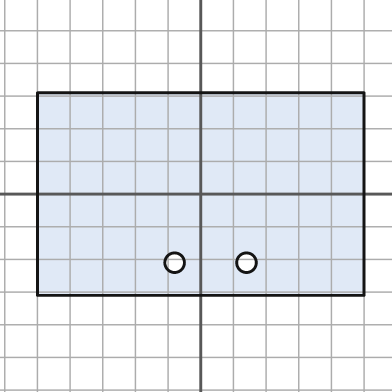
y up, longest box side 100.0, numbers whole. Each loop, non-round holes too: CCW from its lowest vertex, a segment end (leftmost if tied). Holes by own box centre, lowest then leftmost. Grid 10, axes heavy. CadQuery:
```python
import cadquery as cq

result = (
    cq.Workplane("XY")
    .moveTo(-50.0, -31.0)
    .lineTo(50.0, -31.0)
    .lineTo(50.0, 31.0)
    .lineTo(-50.0, 31.0)
    .close()
    .moveTo(-8.0, -21.0)
    .circle(3.0)
    .moveTo(14.0, -21.0)
    .circle(3.0)
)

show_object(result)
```